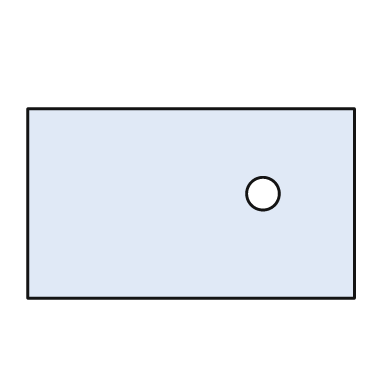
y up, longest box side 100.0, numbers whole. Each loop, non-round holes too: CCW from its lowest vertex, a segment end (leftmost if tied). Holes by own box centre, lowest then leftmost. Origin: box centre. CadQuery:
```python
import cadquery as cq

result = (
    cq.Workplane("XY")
    .moveTo(-50.0, -29.0)
    .lineTo(50.0, -29.0)
    .lineTo(50.0, 29.0)
    .lineTo(-50.0, 29.0)
    .close()
    .moveTo(22.0, 3.0)
    .circle(5.0)
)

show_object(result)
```